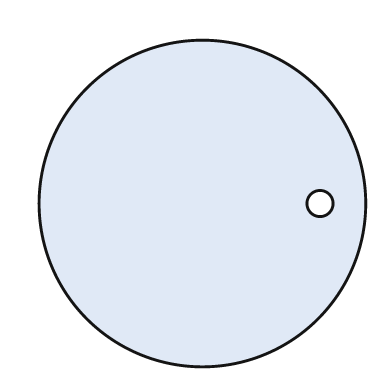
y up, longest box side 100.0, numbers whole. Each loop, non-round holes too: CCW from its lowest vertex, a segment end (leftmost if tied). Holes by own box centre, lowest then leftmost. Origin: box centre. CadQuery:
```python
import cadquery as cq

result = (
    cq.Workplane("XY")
    .moveTo(0.0, 0.0)
    .circle(50.0)
    .moveTo(36.0, 0.0)
    .circle(4.0)
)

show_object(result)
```